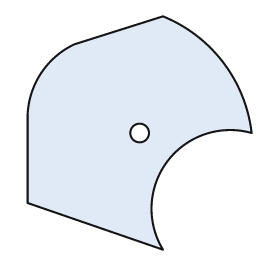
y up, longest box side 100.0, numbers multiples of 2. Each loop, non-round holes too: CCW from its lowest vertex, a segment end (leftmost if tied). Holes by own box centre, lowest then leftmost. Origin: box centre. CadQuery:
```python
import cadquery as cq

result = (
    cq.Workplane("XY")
    .moveTo(10.0, -50.0)
    .threePointArc((12.0, -12.0), (48.0, 0.0))
    .threePointArc((36.0, 30.0), (10.0, 50.0))
    .lineTo(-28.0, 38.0)
    .threePointArc((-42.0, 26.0), (-48.0, 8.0))
    .lineTo(-48.0, -30.0)
    .close()
    .moveTo(0.0, 0.0)
    .circle(4.0)
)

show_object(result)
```